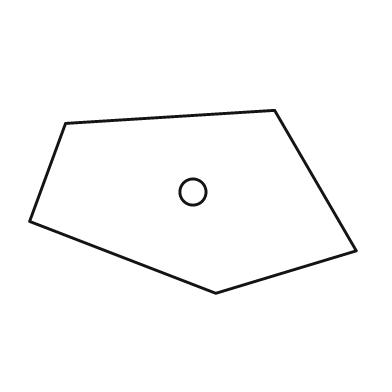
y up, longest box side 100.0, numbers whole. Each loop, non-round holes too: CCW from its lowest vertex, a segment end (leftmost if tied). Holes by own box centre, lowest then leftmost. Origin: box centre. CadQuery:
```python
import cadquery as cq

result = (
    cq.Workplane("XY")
    .moveTo(7.0, -28.0)
    .lineTo(50.0, -15.0)
    .lineTo(25.0, 28.0)
    .lineTo(-39.0, 24.0)
    .lineTo(-50.0, -6.0)
    .close()
    .moveTo(0.0, 3.0)
    .circle(4.0)
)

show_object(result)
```